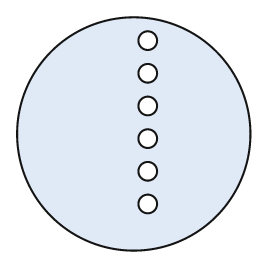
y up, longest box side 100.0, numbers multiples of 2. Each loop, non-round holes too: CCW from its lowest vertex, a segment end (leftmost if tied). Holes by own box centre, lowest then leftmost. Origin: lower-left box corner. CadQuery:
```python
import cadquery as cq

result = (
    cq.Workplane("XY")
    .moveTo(50.0, 50.0)
    .circle(50.0)
    .moveTo(56.0, 20.0)
    .circle(4.0)
    .moveTo(56.0, 34.0)
    .circle(4.0)
    .moveTo(56.0, 48.0)
    .circle(4.0)
    .moveTo(56.0, 62.0)
    .circle(4.0)
    .moveTo(56.0, 76.0)
    .circle(4.0)
    .moveTo(56.0, 90.0)
    .circle(4.0)
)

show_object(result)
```